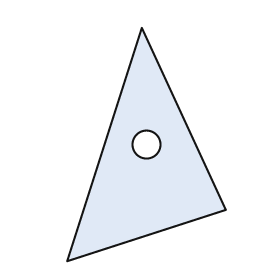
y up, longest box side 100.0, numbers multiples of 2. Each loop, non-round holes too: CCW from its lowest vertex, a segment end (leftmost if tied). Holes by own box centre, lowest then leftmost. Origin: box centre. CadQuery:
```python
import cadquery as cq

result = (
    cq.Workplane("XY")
    .moveTo(-34.0, -50.0)
    .lineTo(34.0, -28.0)
    .lineTo(-2.0, 50.0)
    .close()
    .moveTo(0.0, 0.0)
    .circle(6.0)
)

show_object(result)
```